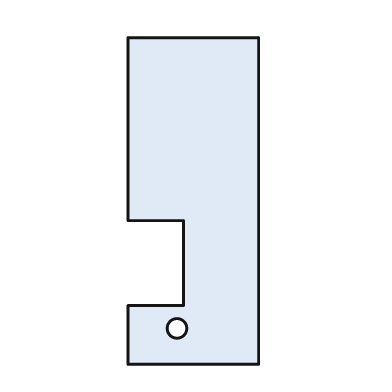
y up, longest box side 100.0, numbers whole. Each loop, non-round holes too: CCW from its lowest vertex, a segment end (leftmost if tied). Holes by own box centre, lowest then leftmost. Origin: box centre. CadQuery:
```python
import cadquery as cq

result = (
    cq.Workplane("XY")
    .moveTo(-20.0, -50.0)
    .lineTo(20.0, -50.0)
    .lineTo(20.0, 50.0)
    .lineTo(-20.0, 50.0)
    .lineTo(-20.0, -6.0)
    .lineTo(-3.0, -6.0)
    .lineTo(-3.0, -32.0)
    .lineTo(-20.0, -32.0)
    .close()
    .moveTo(-5.0, -39.0)
    .circle(3.0)
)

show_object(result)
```